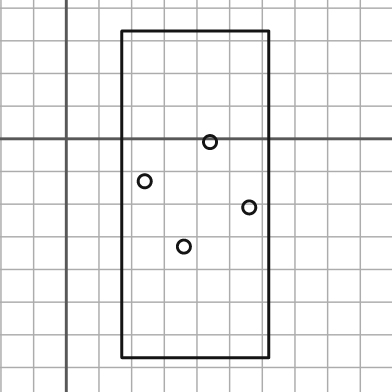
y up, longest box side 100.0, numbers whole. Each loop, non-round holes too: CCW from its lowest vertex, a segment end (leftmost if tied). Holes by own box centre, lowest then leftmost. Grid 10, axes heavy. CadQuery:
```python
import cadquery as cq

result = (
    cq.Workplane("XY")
    .moveTo(17.0, -67.0)
    .lineTo(62.0, -67.0)
    .lineTo(62.0, 33.0)
    .lineTo(17.0, 33.0)
    .close()
    .moveTo(36.0, -33.0)
    .circle(2.0)
    .moveTo(56.0, -21.0)
    .circle(2.0)
    .moveTo(24.0, -13.0)
    .circle(2.0)
    .moveTo(44.0, -1.0)
    .circle(2.0)
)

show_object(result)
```